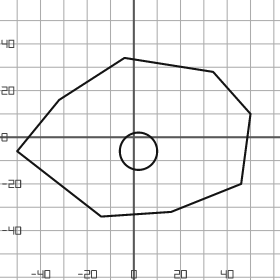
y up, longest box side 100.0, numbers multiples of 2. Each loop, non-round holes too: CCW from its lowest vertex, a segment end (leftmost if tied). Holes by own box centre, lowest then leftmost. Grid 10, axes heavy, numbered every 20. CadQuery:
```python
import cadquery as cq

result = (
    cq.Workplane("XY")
    .moveTo(-14.0, -34.0)
    .lineTo(16.0, -32.0)
    .lineTo(46.0, -20.0)
    .lineTo(50.0, 10.0)
    .lineTo(34.0, 28.0)
    .lineTo(-4.0, 34.0)
    .lineTo(-32.0, 16.0)
    .lineTo(-50.0, -6.0)
    .close()
    .moveTo(2.0, -6.0)
    .circle(8.0)
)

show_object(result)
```